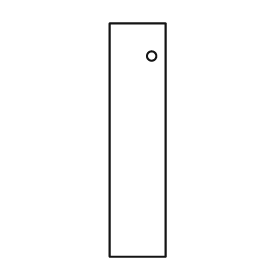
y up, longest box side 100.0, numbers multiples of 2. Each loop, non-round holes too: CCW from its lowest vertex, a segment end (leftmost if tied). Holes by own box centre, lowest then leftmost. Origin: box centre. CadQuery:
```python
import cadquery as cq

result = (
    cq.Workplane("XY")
    .moveTo(-12.0, -50.0)
    .lineTo(12.0, -50.0)
    .lineTo(12.0, 50.0)
    .lineTo(-12.0, 50.0)
    .close()
    .moveTo(6.0, 36.0)
    .circle(2.0)
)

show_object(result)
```